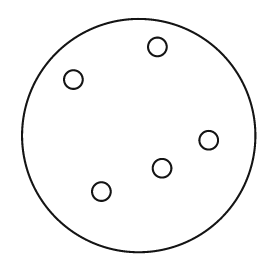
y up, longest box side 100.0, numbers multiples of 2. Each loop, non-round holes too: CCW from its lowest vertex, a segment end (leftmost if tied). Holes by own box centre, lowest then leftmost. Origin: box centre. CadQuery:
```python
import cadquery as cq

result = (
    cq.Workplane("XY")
    .moveTo(0.0, 0.0)
    .circle(50.0)
    .moveTo(-16.0, -24.0)
    .circle(4.0)
    .moveTo(10.0, -14.0)
    .circle(4.0)
    .moveTo(30.0, -2.0)
    .circle(4.0)
    .moveTo(-28.0, 24.0)
    .circle(4.0)
    .moveTo(8.0, 38.0)
    .circle(4.0)
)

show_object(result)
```